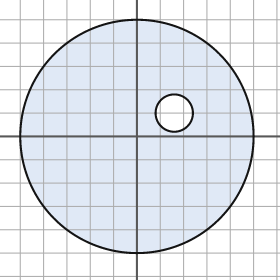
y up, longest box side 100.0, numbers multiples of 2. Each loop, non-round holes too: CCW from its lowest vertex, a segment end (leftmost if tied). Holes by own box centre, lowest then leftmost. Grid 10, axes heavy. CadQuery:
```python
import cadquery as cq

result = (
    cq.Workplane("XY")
    .moveTo(0.0, 0.0)
    .circle(50.0)
    .moveTo(16.0, 10.0)
    .circle(8.0)
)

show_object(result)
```